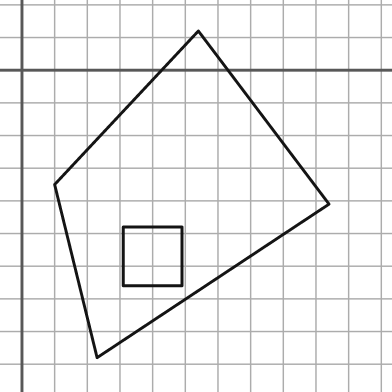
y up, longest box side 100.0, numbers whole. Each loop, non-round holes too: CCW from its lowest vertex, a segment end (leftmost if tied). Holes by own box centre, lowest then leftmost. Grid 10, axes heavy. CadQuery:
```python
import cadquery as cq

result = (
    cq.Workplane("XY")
    .moveTo(23.0, -88.0)
    .lineTo(94.0, -41.0)
    .lineTo(54.0, 12.0)
    .lineTo(10.0, -35.0)
    .close()
    .moveTo(31.0, -66.0)
    .lineTo(49.0, -66.0)
    .lineTo(49.0, -48.0)
    .lineTo(31.0, -48.0)
    .close()
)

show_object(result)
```